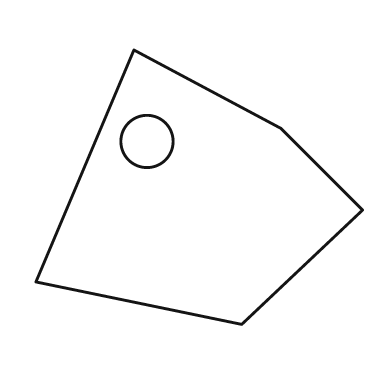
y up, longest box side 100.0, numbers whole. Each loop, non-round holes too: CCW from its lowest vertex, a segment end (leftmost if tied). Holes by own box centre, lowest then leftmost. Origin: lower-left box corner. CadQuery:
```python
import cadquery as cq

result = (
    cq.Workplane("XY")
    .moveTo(63.0, 0.0)
    .lineTo(100.0, 35.0)
    .lineTo(75.0, 60.0)
    .lineTo(30.0, 84.0)
    .lineTo(0.0, 13.0)
    .close()
    .moveTo(34.0, 56.0)
    .circle(8.0)
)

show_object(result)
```